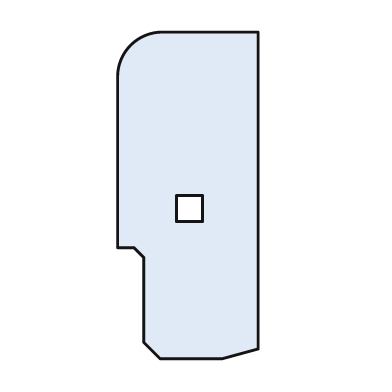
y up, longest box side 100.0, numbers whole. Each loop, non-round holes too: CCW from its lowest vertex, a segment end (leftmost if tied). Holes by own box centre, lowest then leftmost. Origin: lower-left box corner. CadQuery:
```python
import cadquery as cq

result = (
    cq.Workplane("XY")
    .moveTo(13.0, 0.0)
    .lineTo(32.0, 0.0)
    .lineTo(43.0, 3.0)
    .lineTo(43.0, 100.0)
    .lineTo(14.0, 100.0)
    .threePointArc((4.0, 96.0), (0.0, 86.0))
    .lineTo(0.0, 34.0)
    .lineTo(5.0, 34.0)
    .lineTo(8.0, 31.0)
    .lineTo(8.0, 5.0)
    .close()
    .moveTo(18.0, 42.0)
    .lineTo(26.0, 42.0)
    .lineTo(26.0, 50.0)
    .lineTo(18.0, 50.0)
    .close()
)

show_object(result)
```